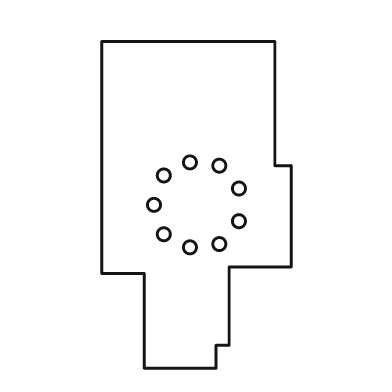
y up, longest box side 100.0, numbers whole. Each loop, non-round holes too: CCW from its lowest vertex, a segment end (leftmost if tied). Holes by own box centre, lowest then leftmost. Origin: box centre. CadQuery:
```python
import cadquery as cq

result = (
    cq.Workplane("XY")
    .moveTo(-16.0, -50.0)
    .lineTo(6.0, -50.0)
    .lineTo(6.0, -43.0)
    .lineTo(10.0, -43.0)
    .lineTo(10.0, -19.0)
    .lineTo(29.0, -19.0)
    .lineTo(29.0, 12.0)
    .lineTo(24.0, 12.0)
    .lineTo(24.0, 50.0)
    .lineTo(-29.0, 50.0)
    .lineTo(-29.0, -21.0)
    .lineTo(-16.0, -21.0)
    .close()
    .moveTo(-2.0, -13.0)
    .circle(2.0)
    .moveTo(7.0, -12.0)
    .circle(2.0)
    .moveTo(-10.0, -9.0)
    .circle(2.0)
    .moveTo(13.0, -5.0)
    .circle(2.0)
    .moveTo(-13.0, 0.0)
    .circle(2.0)
    .moveTo(13.0, 5.0)
    .circle(2.0)
    .moveTo(-10.0, 9.0)
    .circle(2.0)
    .moveTo(7.0, 12.0)
    .circle(2.0)
    .moveTo(-2.0, 13.0)
    .circle(2.0)
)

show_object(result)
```